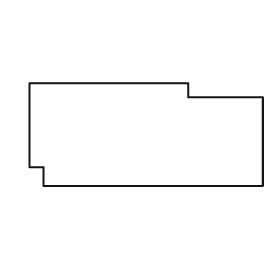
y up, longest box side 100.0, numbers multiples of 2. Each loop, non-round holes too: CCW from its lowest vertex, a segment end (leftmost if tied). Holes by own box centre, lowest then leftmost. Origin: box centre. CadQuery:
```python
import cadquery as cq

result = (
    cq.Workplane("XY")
    .moveTo(-44.0, -22.0)
    .lineTo(50.0, -22.0)
    .lineTo(50.0, 16.0)
    .lineTo(18.0, 16.0)
    .lineTo(18.0, 22.0)
    .lineTo(-50.0, 22.0)
    .lineTo(-50.0, -14.0)
    .lineTo(-44.0, -14.0)
    .close()
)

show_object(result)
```